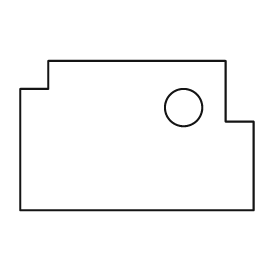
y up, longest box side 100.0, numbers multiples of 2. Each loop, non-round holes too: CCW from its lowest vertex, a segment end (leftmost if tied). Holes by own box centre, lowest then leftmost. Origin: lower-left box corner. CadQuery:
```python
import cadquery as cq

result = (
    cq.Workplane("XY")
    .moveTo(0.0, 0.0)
    .lineTo(100.0, 0.0)
    .lineTo(100.0, 38.0)
    .lineTo(88.0, 38.0)
    .lineTo(88.0, 64.0)
    .lineTo(12.0, 64.0)
    .lineTo(12.0, 52.0)
    .lineTo(0.0, 52.0)
    .close()
    .moveTo(70.0, 44.0)
    .circle(8.0)
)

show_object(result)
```